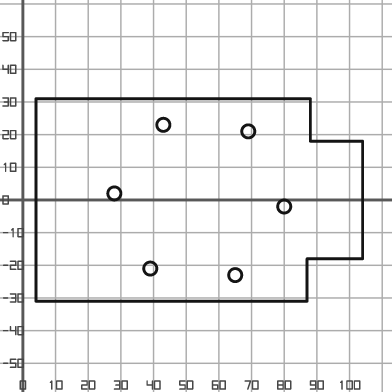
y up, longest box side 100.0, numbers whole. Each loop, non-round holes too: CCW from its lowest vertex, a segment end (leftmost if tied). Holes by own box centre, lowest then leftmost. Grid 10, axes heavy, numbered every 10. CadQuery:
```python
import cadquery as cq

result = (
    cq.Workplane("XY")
    .moveTo(4.0, -31.0)
    .lineTo(87.0, -31.0)
    .lineTo(87.0, -18.0)
    .lineTo(104.0, -18.0)
    .lineTo(104.0, 18.0)
    .lineTo(88.0, 18.0)
    .lineTo(88.0, 31.0)
    .lineTo(4.0, 31.0)
    .close()
    .moveTo(65.0, -23.0)
    .circle(2.0)
    .moveTo(39.0, -21.0)
    .circle(2.0)
    .moveTo(80.0, -2.0)
    .circle(2.0)
    .moveTo(28.0, 2.0)
    .circle(2.0)
    .moveTo(69.0, 21.0)
    .circle(2.0)
    .moveTo(43.0, 23.0)
    .circle(2.0)
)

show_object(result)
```